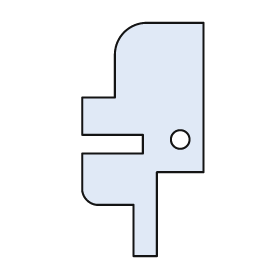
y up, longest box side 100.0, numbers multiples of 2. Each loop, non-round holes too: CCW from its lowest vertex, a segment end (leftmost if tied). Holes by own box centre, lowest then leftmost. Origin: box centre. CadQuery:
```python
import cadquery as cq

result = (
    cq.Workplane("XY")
    .moveTo(-4.0, -50.0)
    .lineTo(6.0, -50.0)
    .lineTo(6.0, -14.0)
    .lineTo(26.0, -14.0)
    .lineTo(26.0, 50.0)
    .lineTo(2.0, 50.0)
    .threePointArc((-8.0, 46.0), (-12.0, 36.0))
    .lineTo(-12.0, 18.0)
    .lineTo(-26.0, 18.0)
    .lineTo(-26.0, 2.0)
    .lineTo(0.0, 2.0)
    .lineTo(0.0, -6.0)
    .lineTo(-26.0, -6.0)
    .lineTo(-26.0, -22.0)
    .threePointArc((-24.0, -26.0), (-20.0, -28.0))
    .lineTo(-4.0, -28.0)
    .close()
    .moveTo(16.0, 0.0)
    .circle(4.0)
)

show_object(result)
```